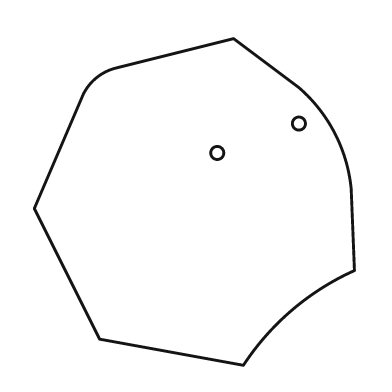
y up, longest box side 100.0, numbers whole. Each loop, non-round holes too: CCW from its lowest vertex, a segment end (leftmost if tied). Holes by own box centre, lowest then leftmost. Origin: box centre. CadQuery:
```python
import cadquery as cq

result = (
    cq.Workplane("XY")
    .moveTo(15.0, -50.0)
    .threePointArc((30.0, -33.0), (49.0, -21.0))
    .lineTo(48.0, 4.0)
    .threePointArc((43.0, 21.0), (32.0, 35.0))
    .lineTo(12.0, 50.0)
    .lineTo(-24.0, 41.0)
    .threePointArc((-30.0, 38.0), (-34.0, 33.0))
    .lineTo(-49.0, -2.0)
    .lineTo(-29.0, -42.0)
    .close()
    .moveTo(7.0, 15.0)
    .circle(2.0)
    .moveTo(32.0, 24.0)
    .circle(2.0)
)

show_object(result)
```